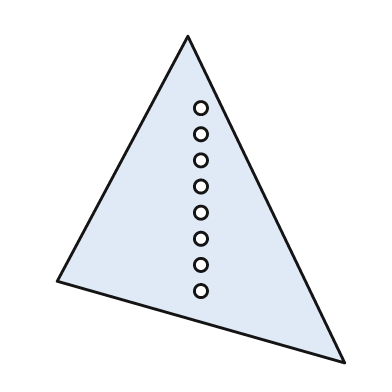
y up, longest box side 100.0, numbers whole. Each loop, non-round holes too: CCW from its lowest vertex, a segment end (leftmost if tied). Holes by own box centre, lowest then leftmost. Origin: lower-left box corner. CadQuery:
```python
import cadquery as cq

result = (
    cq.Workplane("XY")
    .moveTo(88.0, 0.0)
    .lineTo(40.0, 100.0)
    .lineTo(0.0, 25.0)
    .close()
    .moveTo(44.0, 22.0)
    .circle(2.0)
    .moveTo(44.0, 30.0)
    .circle(2.0)
    .moveTo(44.0, 38.0)
    .circle(2.0)
    .moveTo(44.0, 46.0)
    .circle(2.0)
    .moveTo(44.0, 54.0)
    .circle(2.0)
    .moveTo(44.0, 62.0)
    .circle(2.0)
    .moveTo(44.0, 70.0)
    .circle(2.0)
    .moveTo(44.0, 78.0)
    .circle(2.0)
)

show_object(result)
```